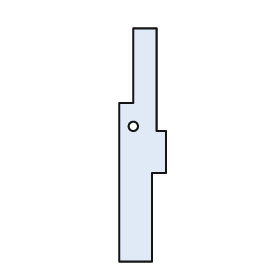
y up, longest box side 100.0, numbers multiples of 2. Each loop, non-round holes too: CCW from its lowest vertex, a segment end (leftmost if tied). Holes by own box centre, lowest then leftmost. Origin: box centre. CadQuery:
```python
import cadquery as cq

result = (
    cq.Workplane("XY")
    .moveTo(-10.0, -50.0)
    .lineTo(4.0, -50.0)
    .lineTo(4.0, -12.0)
    .lineTo(10.0, -12.0)
    .lineTo(10.0, 6.0)
    .lineTo(6.0, 6.0)
    .lineTo(6.0, 50.0)
    .lineTo(-4.0, 50.0)
    .lineTo(-4.0, 18.0)
    .lineTo(-10.0, 18.0)
    .close()
    .moveTo(-4.0, 8.0)
    .circle(2.0)
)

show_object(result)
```